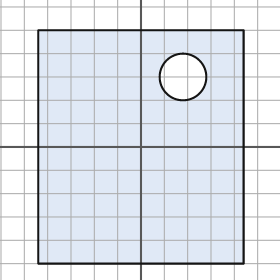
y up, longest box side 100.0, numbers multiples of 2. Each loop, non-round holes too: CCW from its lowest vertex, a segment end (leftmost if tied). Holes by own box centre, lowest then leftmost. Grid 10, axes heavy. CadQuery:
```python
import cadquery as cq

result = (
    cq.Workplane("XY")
    .moveTo(-44.0, -50.0)
    .lineTo(44.0, -50.0)
    .lineTo(44.0, 50.0)
    .lineTo(-44.0, 50.0)
    .close()
    .moveTo(18.0, 30.0)
    .circle(10.0)
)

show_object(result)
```